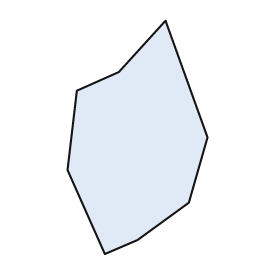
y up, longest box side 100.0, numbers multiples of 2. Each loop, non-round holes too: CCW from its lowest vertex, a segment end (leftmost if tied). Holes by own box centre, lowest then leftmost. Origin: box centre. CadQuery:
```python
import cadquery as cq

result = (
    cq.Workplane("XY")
    .moveTo(-14.0, -50.0)
    .lineTo(0.0, -44.0)
    .lineTo(22.0, -28.0)
    .lineTo(30.0, 0.0)
    .lineTo(12.0, 50.0)
    .lineTo(-8.0, 28.0)
    .lineTo(-26.0, 20.0)
    .lineTo(-30.0, -14.0)
    .close()
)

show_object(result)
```